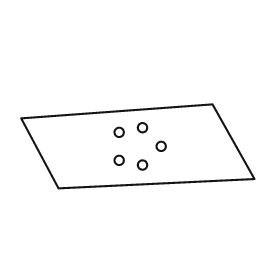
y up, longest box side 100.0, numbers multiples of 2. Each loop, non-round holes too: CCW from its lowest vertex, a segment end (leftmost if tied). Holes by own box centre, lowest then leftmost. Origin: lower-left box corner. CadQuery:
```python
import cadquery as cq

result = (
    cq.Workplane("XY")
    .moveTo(16.0, 0.0)
    .lineTo(100.0, 4.0)
    .lineTo(82.0, 36.0)
    .lineTo(0.0, 30.0)
    .close()
    .moveTo(52.0, 10.0)
    .circle(2.0)
    .moveTo(42.0, 12.0)
    .circle(2.0)
    .moveTo(60.0, 18.0)
    .circle(2.0)
    .moveTo(42.0, 24.0)
    .circle(2.0)
    .moveTo(52.0, 26.0)
    .circle(2.0)
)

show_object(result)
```